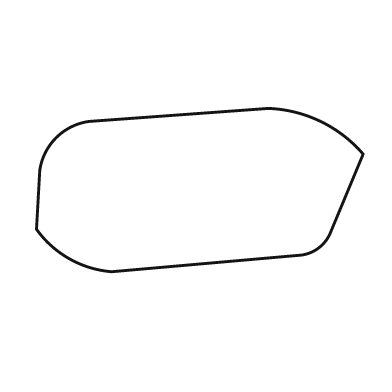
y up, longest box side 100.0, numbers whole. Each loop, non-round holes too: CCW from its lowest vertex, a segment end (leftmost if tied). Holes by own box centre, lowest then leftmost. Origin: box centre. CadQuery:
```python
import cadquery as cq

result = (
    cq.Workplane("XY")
    .moveTo(-27.0, -25.0)
    .lineTo(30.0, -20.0)
    .threePointArc((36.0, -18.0), (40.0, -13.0))
    .lineTo(50.0, 11.0)
    .threePointArc((37.0, 21.0), (21.0, 25.0))
    .lineTo(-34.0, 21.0)
    .threePointArc((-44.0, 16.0), (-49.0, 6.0))
    .lineTo(-50.0, -12.0)
    .threePointArc((-40.0, -21.0), (-27.0, -25.0))
    .close()
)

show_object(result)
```